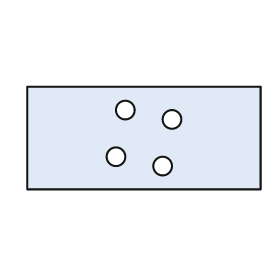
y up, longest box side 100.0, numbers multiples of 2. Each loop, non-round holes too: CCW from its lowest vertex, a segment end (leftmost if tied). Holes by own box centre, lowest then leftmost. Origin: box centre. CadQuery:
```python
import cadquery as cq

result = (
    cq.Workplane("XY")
    .moveTo(-50.0, -22.0)
    .lineTo(50.0, -22.0)
    .lineTo(50.0, 22.0)
    .lineTo(-50.0, 22.0)
    .close()
    .moveTo(8.0, -12.0)
    .circle(4.0)
    .moveTo(-12.0, -8.0)
    .circle(4.0)
    .moveTo(12.0, 8.0)
    .circle(4.0)
    .moveTo(-8.0, 12.0)
    .circle(4.0)
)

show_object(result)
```